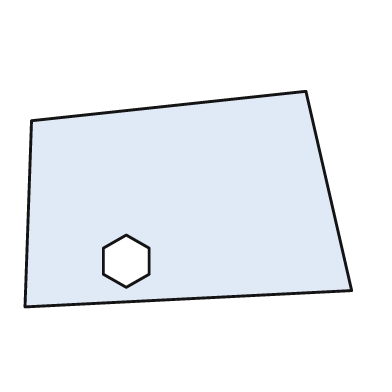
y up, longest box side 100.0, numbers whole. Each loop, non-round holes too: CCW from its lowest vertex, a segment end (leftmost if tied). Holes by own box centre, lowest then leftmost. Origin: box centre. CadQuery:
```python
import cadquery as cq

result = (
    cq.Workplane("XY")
    .moveTo(-50.0, -33.0)
    .lineTo(50.0, -28.0)
    .lineTo(36.0, 33.0)
    .lineTo(-48.0, 24.0)
    .close()
    .moveTo(-19.0, -27.0)
    .lineTo(-12.0, -23.0)
    .lineTo(-12.0, -15.0)
    .lineTo(-19.0, -11.0)
    .lineTo(-26.0, -15.0)
    .lineTo(-26.0, -23.0)
    .close()
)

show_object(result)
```